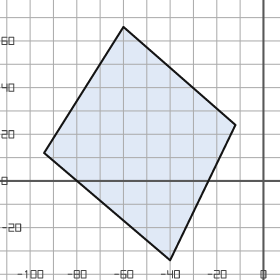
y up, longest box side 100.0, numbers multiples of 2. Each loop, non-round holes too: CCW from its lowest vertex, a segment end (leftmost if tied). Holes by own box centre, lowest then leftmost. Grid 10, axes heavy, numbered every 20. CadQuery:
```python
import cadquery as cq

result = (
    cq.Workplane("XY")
    .moveTo(-40.0, -34.0)
    .lineTo(-12.0, 24.0)
    .lineTo(-60.0, 66.0)
    .lineTo(-94.0, 12.0)
    .close()
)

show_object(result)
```